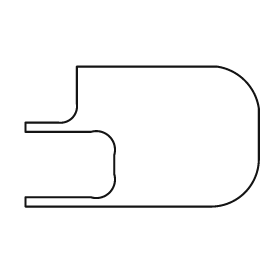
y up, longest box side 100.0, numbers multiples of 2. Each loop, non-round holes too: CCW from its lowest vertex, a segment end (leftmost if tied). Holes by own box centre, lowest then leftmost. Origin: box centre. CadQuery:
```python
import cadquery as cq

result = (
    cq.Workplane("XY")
    .moveTo(-50.0, -30.0)
    .lineTo(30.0, -30.0)
    .threePointArc((44.0, -24.0), (50.0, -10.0))
    .lineTo(50.0, 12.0)
    .threePointArc((44.0, 24.0), (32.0, 30.0))
    .lineTo(-28.0, 30.0)
    .lineTo(-28.0, 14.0)
    .threePointArc((-30.0, 8.0), (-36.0, 6.0))
    .lineTo(-50.0, 6.0)
    .lineTo(-50.0, 2.0)
    .lineTo(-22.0, 2.0)
    .threePointArc((-14.0, 0.0), (-12.0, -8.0))
    .lineTo(-12.0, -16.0)
    .threePointArc((-14.0, -24.0), (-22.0, -26.0))
    .lineTo(-50.0, -26.0)
    .close()
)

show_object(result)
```